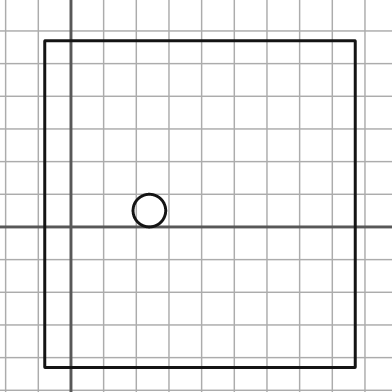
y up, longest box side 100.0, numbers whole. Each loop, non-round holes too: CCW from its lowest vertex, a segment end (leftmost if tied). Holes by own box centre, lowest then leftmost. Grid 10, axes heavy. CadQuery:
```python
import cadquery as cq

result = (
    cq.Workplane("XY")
    .moveTo(-8.0, -43.0)
    .lineTo(87.0, -43.0)
    .lineTo(87.0, 57.0)
    .lineTo(-8.0, 57.0)
    .close()
    .moveTo(24.0, 5.0)
    .circle(5.0)
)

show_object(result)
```